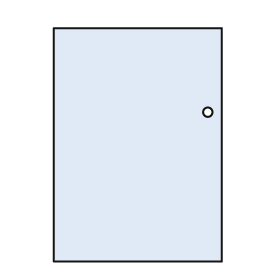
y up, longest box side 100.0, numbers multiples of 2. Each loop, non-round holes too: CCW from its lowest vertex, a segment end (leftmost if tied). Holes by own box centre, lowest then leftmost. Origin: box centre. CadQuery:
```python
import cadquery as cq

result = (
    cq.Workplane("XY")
    .moveTo(-36.0, -50.0)
    .lineTo(36.0, -50.0)
    .lineTo(36.0, 50.0)
    .lineTo(-36.0, 50.0)
    .close()
    .moveTo(30.0, 14.0)
    .circle(2.0)
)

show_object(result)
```